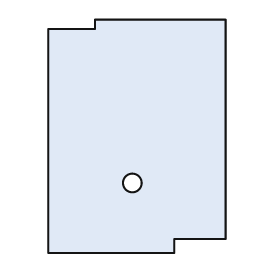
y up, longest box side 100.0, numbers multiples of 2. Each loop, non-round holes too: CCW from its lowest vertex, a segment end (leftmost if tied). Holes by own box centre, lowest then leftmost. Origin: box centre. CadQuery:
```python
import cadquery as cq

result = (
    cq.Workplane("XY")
    .moveTo(-38.0, -50.0)
    .lineTo(16.0, -50.0)
    .lineTo(16.0, -44.0)
    .lineTo(38.0, -44.0)
    .lineTo(38.0, 50.0)
    .lineTo(-18.0, 50.0)
    .lineTo(-18.0, 46.0)
    .lineTo(-38.0, 46.0)
    .close()
    .moveTo(-2.0, -20.0)
    .circle(4.0)
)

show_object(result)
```